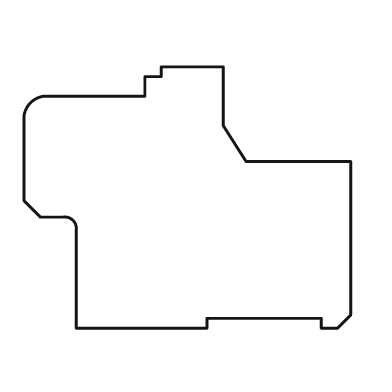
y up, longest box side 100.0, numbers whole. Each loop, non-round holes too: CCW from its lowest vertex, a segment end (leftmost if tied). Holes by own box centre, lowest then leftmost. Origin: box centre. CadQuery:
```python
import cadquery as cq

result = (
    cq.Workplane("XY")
    .moveTo(-34.0, -40.0)
    .lineTo(6.0, -40.0)
    .lineTo(6.0, -37.0)
    .lineTo(41.0, -37.0)
    .lineTo(41.0, -40.0)
    .lineTo(46.0, -40.0)
    .lineTo(50.0, -36.0)
    .lineTo(50.0, 11.0)
    .lineTo(18.0, 11.0)
    .lineTo(11.0, 22.0)
    .lineTo(11.0, 40.0)
    .lineTo(-8.0, 40.0)
    .lineTo(-8.0, 37.0)
    .lineTo(-13.0, 37.0)
    .lineTo(-13.0, 31.0)
    .lineTo(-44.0, 31.0)
    .threePointArc((-48.0, 29.0), (-50.0, 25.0))
    .lineTo(-50.0, -1.0)
    .lineTo(-45.0, -6.0)
    .lineTo(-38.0, -6.0)
    .threePointArc((-35.0, -7.0), (-34.0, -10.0))
    .close()
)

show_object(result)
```